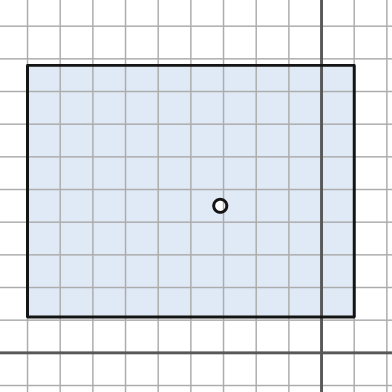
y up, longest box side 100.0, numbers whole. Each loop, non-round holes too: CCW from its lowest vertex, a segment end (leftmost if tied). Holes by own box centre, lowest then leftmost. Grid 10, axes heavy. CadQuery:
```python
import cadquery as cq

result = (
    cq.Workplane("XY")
    .moveTo(-90.0, 11.0)
    .lineTo(10.0, 11.0)
    .lineTo(10.0, 88.0)
    .lineTo(-90.0, 88.0)
    .close()
    .moveTo(-31.0, 45.0)
    .circle(2.0)
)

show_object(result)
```